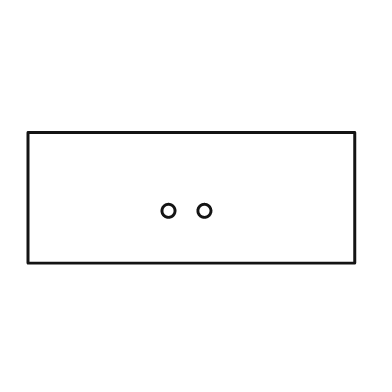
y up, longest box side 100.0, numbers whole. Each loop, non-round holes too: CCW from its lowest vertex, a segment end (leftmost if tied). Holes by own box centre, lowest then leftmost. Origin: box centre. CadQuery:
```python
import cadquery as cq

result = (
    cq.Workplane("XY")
    .moveTo(-50.0, -20.0)
    .lineTo(50.0, -20.0)
    .lineTo(50.0, 20.0)
    .lineTo(-50.0, 20.0)
    .close()
    .moveTo(-7.0, -4.0)
    .circle(2.0)
    .moveTo(4.0, -4.0)
    .circle(2.0)
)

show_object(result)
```